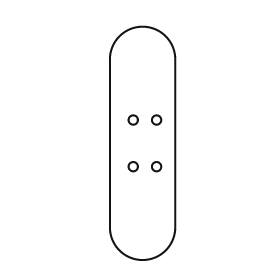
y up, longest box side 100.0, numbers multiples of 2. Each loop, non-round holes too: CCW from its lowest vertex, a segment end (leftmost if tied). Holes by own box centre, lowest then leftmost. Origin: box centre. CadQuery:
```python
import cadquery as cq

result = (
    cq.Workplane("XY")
    .moveTo(-14.0, -36.0)
    .threePointArc((0.0, -50.0), (14.0, -36.0))
    .lineTo(14.0, 36.0)
    .threePointArc((0.0, 50.0), (-14.0, 36.0))
    .close()
    .moveTo(-4.0, -10.0)
    .circle(2.0)
    .moveTo(6.0, -10.0)
    .circle(2.0)
    .moveTo(-4.0, 10.0)
    .circle(2.0)
    .moveTo(6.0, 10.0)
    .circle(2.0)
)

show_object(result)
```